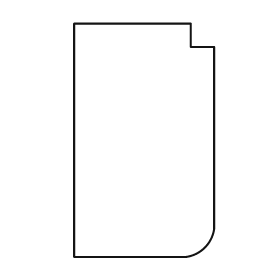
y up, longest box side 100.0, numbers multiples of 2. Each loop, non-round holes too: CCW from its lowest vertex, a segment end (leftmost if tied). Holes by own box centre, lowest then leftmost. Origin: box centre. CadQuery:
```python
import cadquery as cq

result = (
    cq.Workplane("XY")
    .moveTo(-30.0, -50.0)
    .lineTo(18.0, -50.0)
    .threePointArc((26.0, -46.0), (30.0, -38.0))
    .lineTo(30.0, 40.0)
    .lineTo(20.0, 40.0)
    .lineTo(20.0, 50.0)
    .lineTo(-30.0, 50.0)
    .close()
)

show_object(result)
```